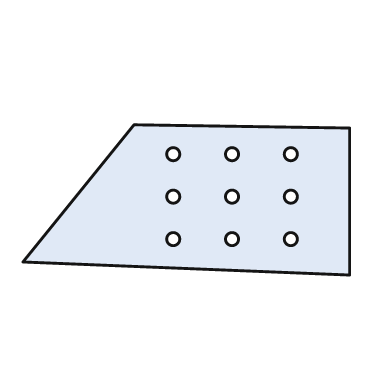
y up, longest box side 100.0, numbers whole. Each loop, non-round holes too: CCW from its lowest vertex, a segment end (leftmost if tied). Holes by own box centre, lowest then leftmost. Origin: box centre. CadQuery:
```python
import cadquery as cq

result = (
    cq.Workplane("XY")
    .moveTo(50.0, -23.0)
    .lineTo(50.0, 22.0)
    .lineTo(-16.0, 23.0)
    .lineTo(-50.0, -19.0)
    .close()
    .moveTo(-4.0, -12.0)
    .circle(2.0)
    .moveTo(14.0, -12.0)
    .circle(2.0)
    .moveTo(32.0, -12.0)
    .circle(2.0)
    .moveTo(-4.0, 1.0)
    .circle(2.0)
    .moveTo(14.0, 1.0)
    .circle(2.0)
    .moveTo(32.0, 1.0)
    .circle(2.0)
    .moveTo(-4.0, 14.0)
    .circle(2.0)
    .moveTo(14.0, 14.0)
    .circle(2.0)
    .moveTo(32.0, 14.0)
    .circle(2.0)
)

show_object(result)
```